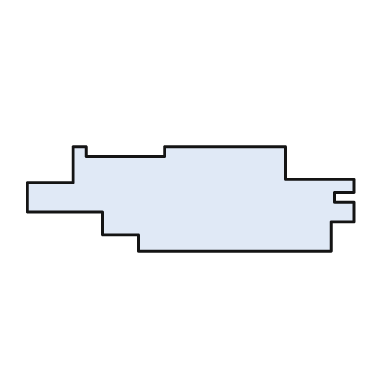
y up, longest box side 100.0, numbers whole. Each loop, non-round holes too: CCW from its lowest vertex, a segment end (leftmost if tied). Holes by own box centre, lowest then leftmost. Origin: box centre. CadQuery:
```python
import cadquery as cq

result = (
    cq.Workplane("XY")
    .moveTo(-16.0, -16.0)
    .lineTo(43.0, -16.0)
    .lineTo(43.0, -7.0)
    .lineTo(50.0, -7.0)
    .lineTo(50.0, -1.0)
    .lineTo(44.0, -1.0)
    .lineTo(44.0, 2.0)
    .lineTo(50.0, 2.0)
    .lineTo(50.0, 6.0)
    .lineTo(29.0, 6.0)
    .lineTo(29.0, 16.0)
    .lineTo(-8.0, 16.0)
    .lineTo(-8.0, 13.0)
    .lineTo(-32.0, 13.0)
    .lineTo(-32.0, 16.0)
    .lineTo(-36.0, 16.0)
    .lineTo(-36.0, 5.0)
    .lineTo(-50.0, 5.0)
    .lineTo(-50.0, -4.0)
    .lineTo(-27.0, -4.0)
    .lineTo(-27.0, -11.0)
    .lineTo(-16.0, -11.0)
    .close()
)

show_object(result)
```